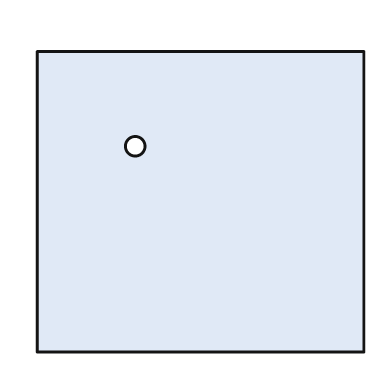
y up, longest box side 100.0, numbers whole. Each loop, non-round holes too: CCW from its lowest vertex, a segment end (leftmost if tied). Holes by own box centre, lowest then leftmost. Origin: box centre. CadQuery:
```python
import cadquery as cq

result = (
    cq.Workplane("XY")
    .moveTo(-50.0, -46.0)
    .lineTo(50.0, -46.0)
    .lineTo(50.0, 46.0)
    .lineTo(-50.0, 46.0)
    .close()
    .moveTo(-20.0, 17.0)
    .circle(3.0)
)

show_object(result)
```